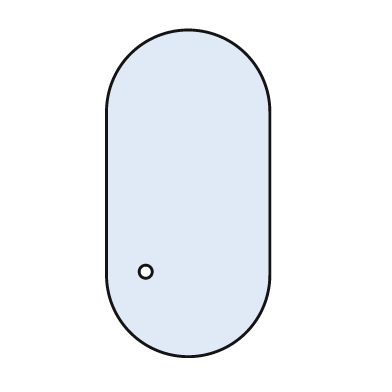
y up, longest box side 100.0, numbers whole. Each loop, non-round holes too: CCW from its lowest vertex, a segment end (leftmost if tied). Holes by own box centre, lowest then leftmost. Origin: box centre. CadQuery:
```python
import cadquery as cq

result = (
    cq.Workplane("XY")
    .moveTo(-25.0, -25.0)
    .threePointArc((0.0, -50.0), (25.0, -25.0))
    .lineTo(25.0, 25.0)
    .threePointArc((0.0, 50.0), (-25.0, 25.0))
    .close()
    .moveTo(-13.0, -24.0)
    .circle(2.0)
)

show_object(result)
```